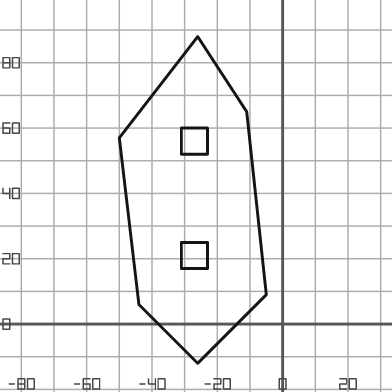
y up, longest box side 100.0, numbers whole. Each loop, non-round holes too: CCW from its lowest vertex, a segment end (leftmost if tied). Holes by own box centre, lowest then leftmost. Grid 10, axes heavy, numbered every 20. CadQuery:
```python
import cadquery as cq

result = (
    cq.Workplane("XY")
    .moveTo(-26.0, -12.0)
    .lineTo(-5.0, 9.0)
    .lineTo(-11.0, 65.0)
    .lineTo(-26.0, 88.0)
    .lineTo(-50.0, 57.0)
    .lineTo(-44.0, 6.0)
    .close()
    .moveTo(-31.0, 17.0)
    .lineTo(-23.0, 17.0)
    .lineTo(-23.0, 25.0)
    .lineTo(-31.0, 25.0)
    .close()
    .moveTo(-31.0, 52.0)
    .lineTo(-23.0, 52.0)
    .lineTo(-23.0, 60.0)
    .lineTo(-31.0, 60.0)
    .close()
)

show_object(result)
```